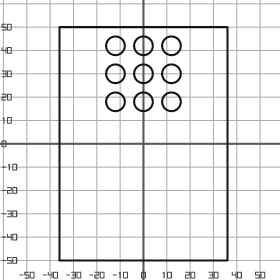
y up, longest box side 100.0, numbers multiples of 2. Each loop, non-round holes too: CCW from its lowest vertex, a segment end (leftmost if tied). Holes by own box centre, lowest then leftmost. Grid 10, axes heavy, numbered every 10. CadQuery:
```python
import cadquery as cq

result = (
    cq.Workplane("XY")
    .moveTo(-36.0, -50.0)
    .lineTo(36.0, -50.0)
    .lineTo(36.0, 50.0)
    .lineTo(-36.0, 50.0)
    .close()
    .moveTo(-12.0, 18.0)
    .circle(4.0)
    .moveTo(0.0, 18.0)
    .circle(4.0)
    .moveTo(12.0, 18.0)
    .circle(4.0)
    .moveTo(-12.0, 30.0)
    .circle(4.0)
    .moveTo(0.0, 30.0)
    .circle(4.0)
    .moveTo(12.0, 30.0)
    .circle(4.0)
    .moveTo(-12.0, 42.0)
    .circle(4.0)
    .moveTo(0.0, 42.0)
    .circle(4.0)
    .moveTo(12.0, 42.0)
    .circle(4.0)
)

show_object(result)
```